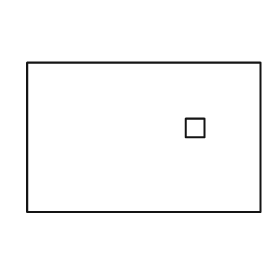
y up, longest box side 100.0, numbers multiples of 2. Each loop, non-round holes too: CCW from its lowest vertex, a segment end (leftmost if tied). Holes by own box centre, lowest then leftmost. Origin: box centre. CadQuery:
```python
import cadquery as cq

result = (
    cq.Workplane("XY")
    .moveTo(-50.0, -32.0)
    .lineTo(50.0, -32.0)
    .lineTo(50.0, 32.0)
    .lineTo(-50.0, 32.0)
    .close()
    .moveTo(18.0, 0.0)
    .lineTo(26.0, 0.0)
    .lineTo(26.0, 8.0)
    .lineTo(18.0, 8.0)
    .close()
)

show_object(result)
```